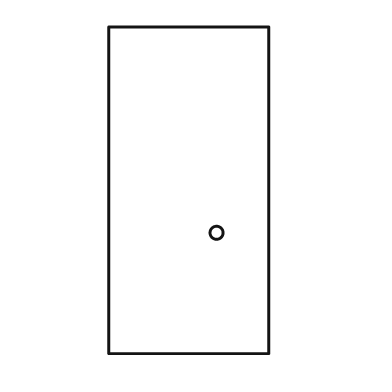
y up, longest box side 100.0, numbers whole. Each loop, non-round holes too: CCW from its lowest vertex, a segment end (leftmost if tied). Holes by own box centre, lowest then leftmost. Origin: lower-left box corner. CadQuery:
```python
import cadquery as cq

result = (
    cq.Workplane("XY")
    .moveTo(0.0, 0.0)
    .lineTo(49.0, 0.0)
    .lineTo(49.0, 100.0)
    .lineTo(0.0, 100.0)
    .close()
    .moveTo(33.0, 37.0)
    .circle(2.0)
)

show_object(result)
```